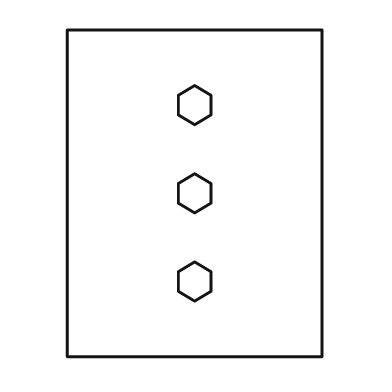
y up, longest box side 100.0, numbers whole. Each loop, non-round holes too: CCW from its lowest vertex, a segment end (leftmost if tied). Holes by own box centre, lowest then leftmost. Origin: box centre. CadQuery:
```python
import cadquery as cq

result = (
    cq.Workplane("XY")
    .moveTo(-39.0, -50.0)
    .lineTo(39.0, -50.0)
    .lineTo(39.0, 50.0)
    .lineTo(-39.0, 50.0)
    .close()
    .moveTo(0.0, -33.0)
    .lineTo(5.0, -30.0)
    .lineTo(5.0, -24.0)
    .lineTo(0.0, -21.0)
    .lineTo(-5.0, -24.0)
    .lineTo(-5.0, -30.0)
    .close()
    .moveTo(0.0, -6.0)
    .lineTo(5.0, -3.0)
    .lineTo(5.0, 3.0)
    .lineTo(0.0, 6.0)
    .lineTo(-5.0, 3.0)
    .lineTo(-5.0, -3.0)
    .close()
    .moveTo(0.0, 21.0)
    .lineTo(5.0, 24.0)
    .lineTo(5.0, 30.0)
    .lineTo(0.0, 33.0)
    .lineTo(-5.0, 30.0)
    .lineTo(-5.0, 24.0)
    .close()
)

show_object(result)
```